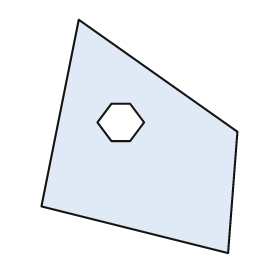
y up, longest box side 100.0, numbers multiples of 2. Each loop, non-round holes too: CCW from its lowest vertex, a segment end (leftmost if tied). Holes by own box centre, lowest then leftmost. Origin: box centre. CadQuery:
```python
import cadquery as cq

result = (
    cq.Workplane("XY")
    .moveTo(38.0, -50.0)
    .lineTo(42.0, 2.0)
    .lineTo(-26.0, 50.0)
    .lineTo(-42.0, -30.0)
    .close()
    .moveTo(-12.0, -2.0)
    .lineTo(-4.0, -2.0)
    .lineTo(2.0, 6.0)
    .lineTo(-4.0, 14.0)
    .lineTo(-12.0, 14.0)
    .lineTo(-18.0, 6.0)
    .close()
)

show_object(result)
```